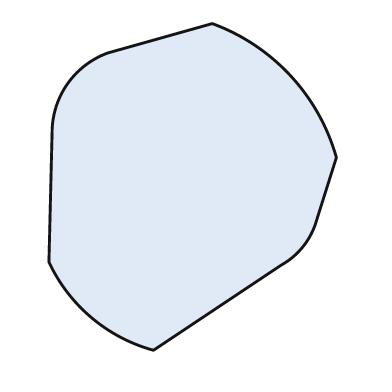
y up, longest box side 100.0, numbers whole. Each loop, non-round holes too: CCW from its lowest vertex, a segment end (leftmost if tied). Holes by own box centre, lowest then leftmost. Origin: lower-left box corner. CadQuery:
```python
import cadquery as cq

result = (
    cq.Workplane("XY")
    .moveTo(32.0, 0.0)
    .lineTo(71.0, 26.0)
    .threePointArc((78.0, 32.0), (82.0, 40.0))
    .lineTo(88.0, 59.0)
    .threePointArc((74.0, 84.0), (50.0, 100.0))
    .lineTo(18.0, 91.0)
    .threePointArc((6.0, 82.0), (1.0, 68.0))
    .lineTo(0.0, 27.0)
    .threePointArc((13.0, 10.0), (32.0, 0.0))
    .close()
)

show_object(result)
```